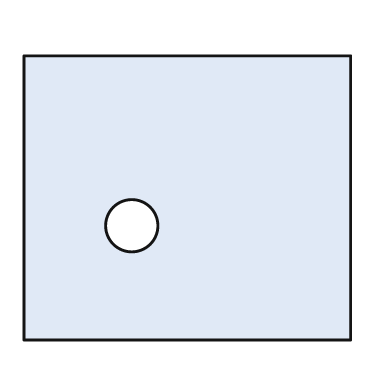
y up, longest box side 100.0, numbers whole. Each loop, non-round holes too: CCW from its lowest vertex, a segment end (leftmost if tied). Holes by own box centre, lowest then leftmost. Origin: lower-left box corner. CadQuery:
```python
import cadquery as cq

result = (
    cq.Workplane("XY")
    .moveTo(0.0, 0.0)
    .lineTo(100.0, 0.0)
    .lineTo(100.0, 87.0)
    .lineTo(0.0, 87.0)
    .close()
    .moveTo(33.0, 35.0)
    .circle(8.0)
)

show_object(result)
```